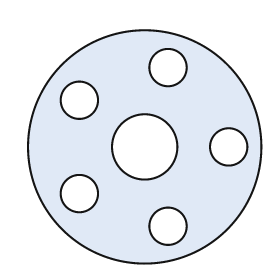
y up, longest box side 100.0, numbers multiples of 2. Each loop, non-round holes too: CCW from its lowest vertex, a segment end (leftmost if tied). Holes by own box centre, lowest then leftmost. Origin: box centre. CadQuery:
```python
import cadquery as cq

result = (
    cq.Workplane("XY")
    .moveTo(0.0, 0.0)
    .circle(50.0)
    .moveTo(10.0, -34.0)
    .circle(8.0)
    .moveTo(-28.0, -20.0)
    .circle(8.0)
    .moveTo(0.0, 0.0)
    .circle(14.0)
    .moveTo(36.0, 0.0)
    .circle(8.0)
    .moveTo(-28.0, 20.0)
    .circle(8.0)
    .moveTo(10.0, 34.0)
    .circle(8.0)
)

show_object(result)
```